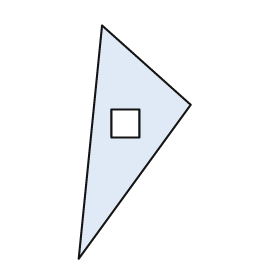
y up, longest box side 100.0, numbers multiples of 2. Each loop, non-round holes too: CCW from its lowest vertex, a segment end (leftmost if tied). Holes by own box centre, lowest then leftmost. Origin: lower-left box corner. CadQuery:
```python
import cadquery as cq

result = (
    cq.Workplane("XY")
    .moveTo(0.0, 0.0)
    .lineTo(48.0, 66.0)
    .lineTo(10.0, 100.0)
    .close()
    .moveTo(14.0, 52.0)
    .lineTo(26.0, 52.0)
    .lineTo(26.0, 64.0)
    .lineTo(14.0, 64.0)
    .close()
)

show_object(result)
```